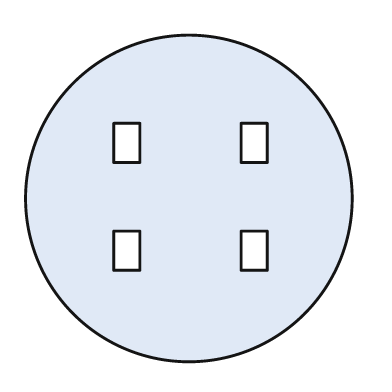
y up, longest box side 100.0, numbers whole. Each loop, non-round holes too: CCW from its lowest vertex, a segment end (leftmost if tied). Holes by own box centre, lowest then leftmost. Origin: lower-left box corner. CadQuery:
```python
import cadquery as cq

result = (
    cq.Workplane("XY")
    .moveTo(50.0, 50.0)
    .circle(50.0)
    .moveTo(27.0, 28.0)
    .lineTo(35.0, 28.0)
    .lineTo(35.0, 40.0)
    .lineTo(27.0, 40.0)
    .close()
    .moveTo(66.0, 28.0)
    .lineTo(74.0, 28.0)
    .lineTo(74.0, 40.0)
    .lineTo(66.0, 40.0)
    .close()
    .moveTo(27.0, 61.0)
    .lineTo(35.0, 61.0)
    .lineTo(35.0, 73.0)
    .lineTo(27.0, 73.0)
    .close()
    .moveTo(66.0, 61.0)
    .lineTo(74.0, 61.0)
    .lineTo(74.0, 73.0)
    .lineTo(66.0, 73.0)
    .close()
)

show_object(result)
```